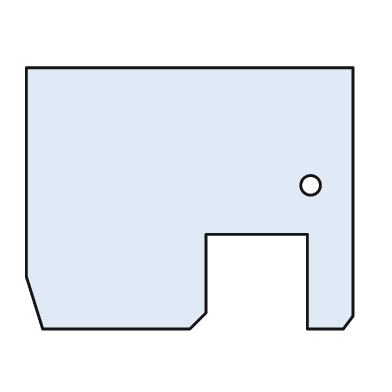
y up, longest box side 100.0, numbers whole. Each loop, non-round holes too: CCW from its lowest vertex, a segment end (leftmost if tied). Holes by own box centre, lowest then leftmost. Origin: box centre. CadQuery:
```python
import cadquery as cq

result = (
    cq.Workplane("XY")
    .moveTo(-45.0, -40.0)
    .lineTo(0.0, -40.0)
    .lineTo(5.0, -35.0)
    .lineTo(5.0, -11.0)
    .lineTo(36.0, -11.0)
    .lineTo(36.0, -40.0)
    .lineTo(47.0, -40.0)
    .lineTo(50.0, -36.0)
    .lineTo(50.0, 40.0)
    .lineTo(-50.0, 40.0)
    .lineTo(-50.0, -24.0)
    .close()
    .moveTo(37.0, 4.0)
    .circle(3.0)
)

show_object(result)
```